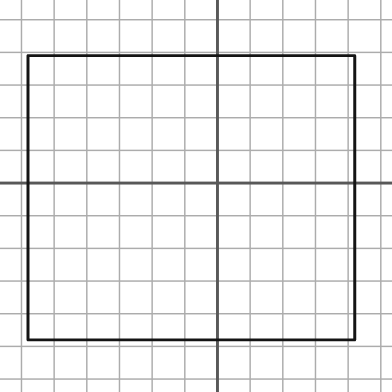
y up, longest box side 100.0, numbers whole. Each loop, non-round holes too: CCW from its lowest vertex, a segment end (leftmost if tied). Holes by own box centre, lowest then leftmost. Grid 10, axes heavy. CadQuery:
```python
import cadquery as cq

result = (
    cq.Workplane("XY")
    .moveTo(-58.0, -48.0)
    .lineTo(42.0, -48.0)
    .lineTo(42.0, 39.0)
    .lineTo(-58.0, 39.0)
    .close()
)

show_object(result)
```